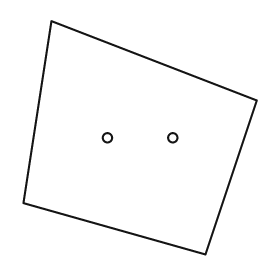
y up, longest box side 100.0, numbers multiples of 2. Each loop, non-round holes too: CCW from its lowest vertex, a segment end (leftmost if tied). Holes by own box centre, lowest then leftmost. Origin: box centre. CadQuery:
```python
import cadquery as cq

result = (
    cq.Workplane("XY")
    .moveTo(28.0, -50.0)
    .lineTo(50.0, 16.0)
    .lineTo(-38.0, 50.0)
    .lineTo(-50.0, -28.0)
    .close()
    .moveTo(-14.0, 0.0)
    .circle(2.0)
    .moveTo(14.0, 0.0)
    .circle(2.0)
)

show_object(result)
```